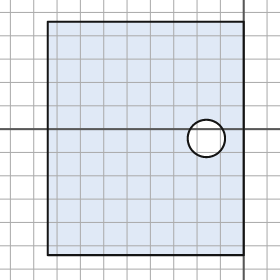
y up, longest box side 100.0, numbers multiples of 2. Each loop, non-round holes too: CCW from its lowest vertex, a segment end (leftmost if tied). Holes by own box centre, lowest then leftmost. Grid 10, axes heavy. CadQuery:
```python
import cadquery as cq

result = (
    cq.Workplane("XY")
    .moveTo(-84.0, -54.0)
    .lineTo(0.0, -54.0)
    .lineTo(0.0, 46.0)
    .lineTo(-84.0, 46.0)
    .close()
    .moveTo(-16.0, -4.0)
    .circle(8.0)
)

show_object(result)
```